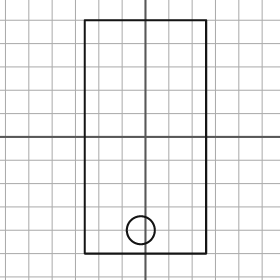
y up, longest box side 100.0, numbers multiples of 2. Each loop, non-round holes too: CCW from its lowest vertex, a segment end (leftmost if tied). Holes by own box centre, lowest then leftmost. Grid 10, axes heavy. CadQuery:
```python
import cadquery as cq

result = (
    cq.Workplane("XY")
    .moveTo(-26.0, -50.0)
    .lineTo(26.0, -50.0)
    .lineTo(26.0, 50.0)
    .lineTo(-26.0, 50.0)
    .close()
    .moveTo(-2.0, -40.0)
    .circle(6.0)
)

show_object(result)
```